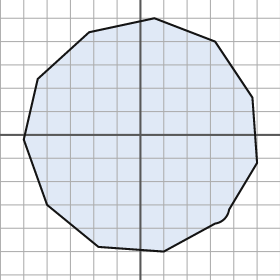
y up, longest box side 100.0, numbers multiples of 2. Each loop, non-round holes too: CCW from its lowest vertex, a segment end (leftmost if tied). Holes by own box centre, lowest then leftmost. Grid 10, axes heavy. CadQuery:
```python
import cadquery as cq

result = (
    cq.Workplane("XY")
    .moveTo(10.0, -50.0)
    .lineTo(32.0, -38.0)
    .threePointArc((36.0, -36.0), (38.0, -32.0))
    .lineTo(50.0, -12.0)
    .lineTo(48.0, 16.0)
    .lineTo(32.0, 40.0)
    .lineTo(6.0, 50.0)
    .lineTo(-22.0, 44.0)
    .lineTo(-44.0, 24.0)
    .lineTo(-50.0, -2.0)
    .lineTo(-40.0, -30.0)
    .lineTo(-18.0, -48.0)
    .close()
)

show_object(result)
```